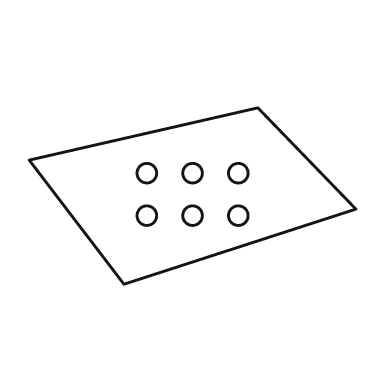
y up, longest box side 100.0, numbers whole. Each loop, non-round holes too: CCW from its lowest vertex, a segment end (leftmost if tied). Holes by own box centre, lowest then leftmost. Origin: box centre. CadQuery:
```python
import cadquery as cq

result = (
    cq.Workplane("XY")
    .moveTo(-21.0, -27.0)
    .lineTo(50.0, -4.0)
    .lineTo(20.0, 27.0)
    .lineTo(-50.0, 11.0)
    .close()
    .moveTo(-14.0, -6.0)
    .circle(3.0)
    .moveTo(0.0, -6.0)
    .circle(3.0)
    .moveTo(14.0, -6.0)
    .circle(3.0)
    .moveTo(-14.0, 7.0)
    .circle(3.0)
    .moveTo(0.0, 7.0)
    .circle(3.0)
    .moveTo(14.0, 7.0)
    .circle(3.0)
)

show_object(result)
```